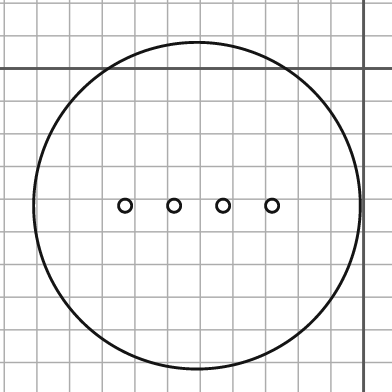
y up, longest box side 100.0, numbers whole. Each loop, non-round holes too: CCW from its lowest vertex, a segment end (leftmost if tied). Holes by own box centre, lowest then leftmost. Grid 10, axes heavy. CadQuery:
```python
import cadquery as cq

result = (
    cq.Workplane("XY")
    .moveTo(-51.0, -42.0)
    .circle(50.0)
    .moveTo(-73.0, -42.0)
    .circle(2.0)
    .moveTo(-58.0, -42.0)
    .circle(2.0)
    .moveTo(-43.0, -42.0)
    .circle(2.0)
    .moveTo(-28.0, -42.0)
    .circle(2.0)
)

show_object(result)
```